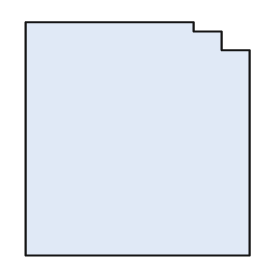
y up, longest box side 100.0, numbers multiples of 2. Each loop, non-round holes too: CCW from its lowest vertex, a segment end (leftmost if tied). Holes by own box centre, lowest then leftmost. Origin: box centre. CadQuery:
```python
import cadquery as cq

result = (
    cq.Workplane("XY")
    .moveTo(-48.0, -50.0)
    .lineTo(48.0, -50.0)
    .lineTo(48.0, 38.0)
    .lineTo(36.0, 38.0)
    .lineTo(36.0, 46.0)
    .lineTo(24.0, 46.0)
    .lineTo(24.0, 50.0)
    .lineTo(-48.0, 50.0)
    .close()
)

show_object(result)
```